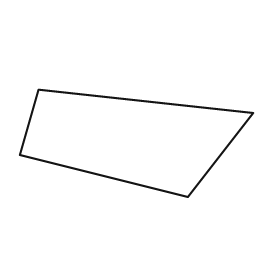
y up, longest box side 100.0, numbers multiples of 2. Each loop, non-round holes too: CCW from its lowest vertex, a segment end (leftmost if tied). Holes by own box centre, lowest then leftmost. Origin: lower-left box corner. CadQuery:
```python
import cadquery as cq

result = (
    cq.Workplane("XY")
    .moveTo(72.0, 0.0)
    .lineTo(100.0, 36.0)
    .lineTo(8.0, 46.0)
    .lineTo(0.0, 18.0)
    .close()
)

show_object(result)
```